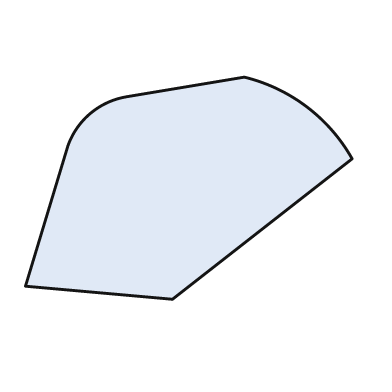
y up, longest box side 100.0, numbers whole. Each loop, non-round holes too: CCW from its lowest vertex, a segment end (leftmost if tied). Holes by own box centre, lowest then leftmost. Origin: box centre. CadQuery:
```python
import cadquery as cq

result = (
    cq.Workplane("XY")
    .moveTo(-5.0, -34.0)
    .lineTo(50.0, 9.0)
    .threePointArc((36.0, 25.0), (17.0, 34.0))
    .lineTo(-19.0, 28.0)
    .threePointArc((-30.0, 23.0), (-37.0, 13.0))
    .lineTo(-50.0, -30.0)
    .close()
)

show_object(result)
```